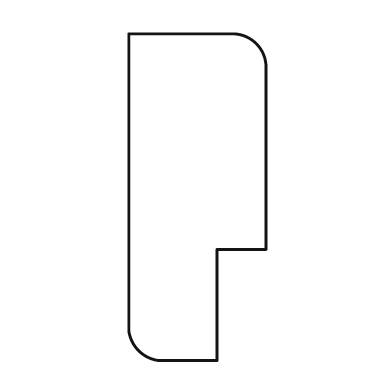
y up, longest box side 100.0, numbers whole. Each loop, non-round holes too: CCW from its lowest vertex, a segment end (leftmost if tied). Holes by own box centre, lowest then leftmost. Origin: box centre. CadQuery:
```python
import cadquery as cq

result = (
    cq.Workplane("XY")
    .moveTo(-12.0, -50.0)
    .lineTo(6.0, -50.0)
    .lineTo(6.0, -16.0)
    .lineTo(21.0, -16.0)
    .lineTo(21.0, 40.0)
    .threePointArc((18.0, 47.0), (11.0, 50.0))
    .lineTo(-21.0, 50.0)
    .lineTo(-21.0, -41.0)
    .threePointArc((-18.0, -47.0), (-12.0, -50.0))
    .close()
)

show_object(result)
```